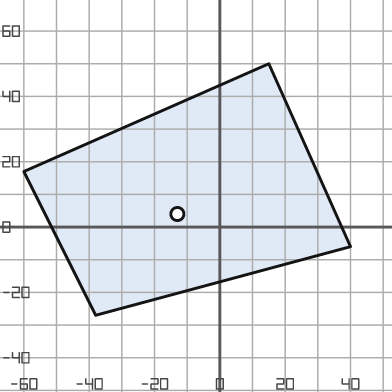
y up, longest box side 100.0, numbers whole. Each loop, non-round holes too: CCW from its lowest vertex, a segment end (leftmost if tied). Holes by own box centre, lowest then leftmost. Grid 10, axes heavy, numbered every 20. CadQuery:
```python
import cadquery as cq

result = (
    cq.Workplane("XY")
    .moveTo(-38.0, -27.0)
    .lineTo(40.0, -6.0)
    .lineTo(15.0, 50.0)
    .lineTo(-60.0, 17.0)
    .close()
    .moveTo(-13.0, 4.0)
    .circle(2.0)
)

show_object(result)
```